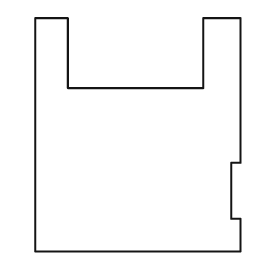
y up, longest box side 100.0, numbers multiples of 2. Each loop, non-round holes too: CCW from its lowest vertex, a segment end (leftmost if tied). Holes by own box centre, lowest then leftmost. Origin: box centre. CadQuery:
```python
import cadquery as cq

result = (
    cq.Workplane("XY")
    .moveTo(-44.0, -50.0)
    .lineTo(44.0, -50.0)
    .lineTo(44.0, -36.0)
    .lineTo(40.0, -36.0)
    .lineTo(40.0, -12.0)
    .lineTo(44.0, -12.0)
    .lineTo(44.0, 50.0)
    .lineTo(28.0, 50.0)
    .lineTo(28.0, 20.0)
    .lineTo(-30.0, 20.0)
    .lineTo(-30.0, 50.0)
    .lineTo(-44.0, 50.0)
    .close()
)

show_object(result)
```